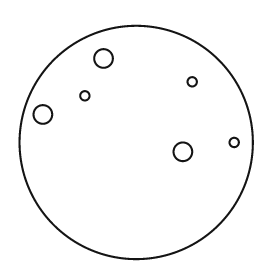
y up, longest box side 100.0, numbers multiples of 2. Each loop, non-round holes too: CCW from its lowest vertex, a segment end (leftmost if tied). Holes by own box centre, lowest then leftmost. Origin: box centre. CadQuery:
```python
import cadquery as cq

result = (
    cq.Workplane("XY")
    .moveTo(0.0, 0.0)
    .circle(50.0)
    .moveTo(20.0, -4.0)
    .circle(4.0)
    .moveTo(42.0, 0.0)
    .circle(2.0)
    .moveTo(-40.0, 12.0)
    .circle(4.0)
    .moveTo(-22.0, 20.0)
    .circle(2.0)
    .moveTo(24.0, 26.0)
    .circle(2.0)
    .moveTo(-14.0, 36.0)
    .circle(4.0)
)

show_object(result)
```